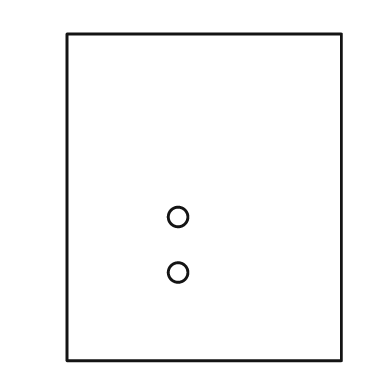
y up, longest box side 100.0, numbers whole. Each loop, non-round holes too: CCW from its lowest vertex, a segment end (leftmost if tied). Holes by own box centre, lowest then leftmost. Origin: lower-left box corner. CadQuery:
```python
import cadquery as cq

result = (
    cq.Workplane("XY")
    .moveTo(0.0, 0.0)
    .lineTo(84.0, 0.0)
    .lineTo(84.0, 100.0)
    .lineTo(0.0, 100.0)
    .close()
    .moveTo(34.0, 27.0)
    .circle(3.0)
    .moveTo(34.0, 44.0)
    .circle(3.0)
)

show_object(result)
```